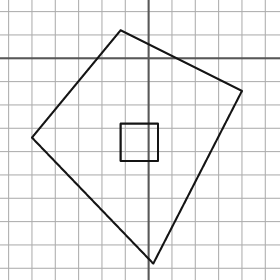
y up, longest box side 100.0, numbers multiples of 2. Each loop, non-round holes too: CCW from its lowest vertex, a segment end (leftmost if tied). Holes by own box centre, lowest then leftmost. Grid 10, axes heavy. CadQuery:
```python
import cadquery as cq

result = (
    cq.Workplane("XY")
    .moveTo(2.0, -88.0)
    .lineTo(40.0, -14.0)
    .lineTo(-12.0, 12.0)
    .lineTo(-50.0, -34.0)
    .close()
    .moveTo(-12.0, -44.0)
    .lineTo(4.0, -44.0)
    .lineTo(4.0, -28.0)
    .lineTo(-12.0, -28.0)
    .close()
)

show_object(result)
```